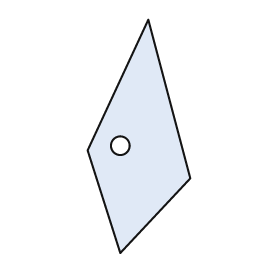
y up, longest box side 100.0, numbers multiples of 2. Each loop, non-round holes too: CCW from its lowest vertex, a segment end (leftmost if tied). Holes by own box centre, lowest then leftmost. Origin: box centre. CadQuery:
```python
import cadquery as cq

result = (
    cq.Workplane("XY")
    .moveTo(-8.0, -50.0)
    .lineTo(22.0, -18.0)
    .lineTo(4.0, 50.0)
    .lineTo(-22.0, -6.0)
    .close()
    .moveTo(-8.0, -4.0)
    .circle(4.0)
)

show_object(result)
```